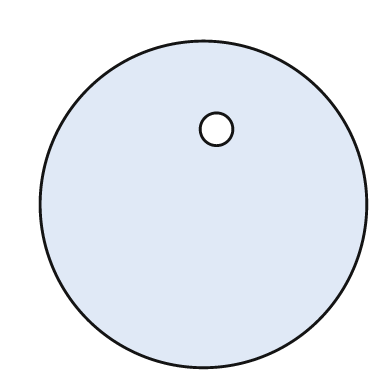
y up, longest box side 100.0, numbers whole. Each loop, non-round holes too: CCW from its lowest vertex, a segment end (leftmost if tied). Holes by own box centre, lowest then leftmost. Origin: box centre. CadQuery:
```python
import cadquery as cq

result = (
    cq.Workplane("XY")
    .moveTo(0.0, 0.0)
    .circle(50.0)
    .moveTo(4.0, 23.0)
    .circle(5.0)
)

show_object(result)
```